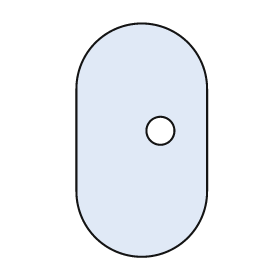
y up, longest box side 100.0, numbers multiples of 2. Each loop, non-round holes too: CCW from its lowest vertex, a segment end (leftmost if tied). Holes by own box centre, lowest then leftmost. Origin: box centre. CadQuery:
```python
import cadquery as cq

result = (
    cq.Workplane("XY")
    .moveTo(-28.0, -22.0)
    .threePointArc((0.0, -50.0), (28.0, -22.0))
    .lineTo(28.0, 22.0)
    .threePointArc((0.0, 50.0), (-28.0, 22.0))
    .close()
    .moveTo(8.0, 4.0)
    .circle(6.0)
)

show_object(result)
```